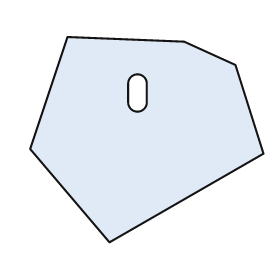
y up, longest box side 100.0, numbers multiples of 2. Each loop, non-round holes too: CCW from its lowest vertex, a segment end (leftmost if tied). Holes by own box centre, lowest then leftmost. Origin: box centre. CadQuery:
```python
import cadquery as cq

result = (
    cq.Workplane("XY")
    .moveTo(-16.0, -44.0)
    .lineTo(50.0, -6.0)
    .lineTo(38.0, 32.0)
    .lineTo(16.0, 42.0)
    .lineTo(-34.0, 44.0)
    .lineTo(-50.0, -4.0)
    .close()
    .moveTo(-8.0, 16.0)
    .threePointArc((-4.0, 12.0), (0.0, 16.0))
    .lineTo(0.0, 24.0)
    .threePointArc((-4.0, 28.0), (-8.0, 24.0))
    .close()
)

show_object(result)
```